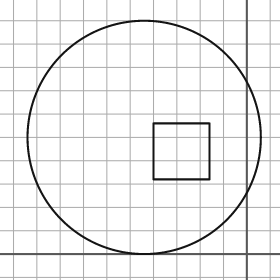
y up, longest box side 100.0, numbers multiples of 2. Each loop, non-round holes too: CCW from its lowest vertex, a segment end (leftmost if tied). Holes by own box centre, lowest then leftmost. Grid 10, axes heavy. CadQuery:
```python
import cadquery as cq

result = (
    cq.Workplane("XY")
    .moveTo(-44.0, 50.0)
    .circle(50.0)
    .moveTo(-40.0, 32.0)
    .lineTo(-16.0, 32.0)
    .lineTo(-16.0, 56.0)
    .lineTo(-40.0, 56.0)
    .close()
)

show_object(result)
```